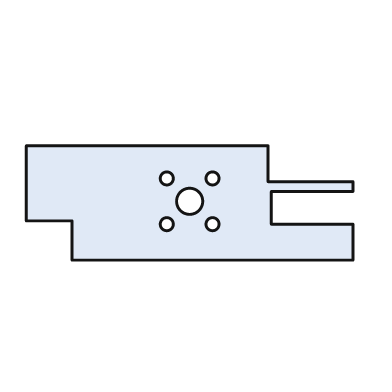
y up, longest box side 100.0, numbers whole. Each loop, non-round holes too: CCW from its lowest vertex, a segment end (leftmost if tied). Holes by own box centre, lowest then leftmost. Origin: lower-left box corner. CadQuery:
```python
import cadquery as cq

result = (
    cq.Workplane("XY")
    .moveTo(14.0, 0.0)
    .lineTo(100.0, 0.0)
    .lineTo(100.0, 11.0)
    .lineTo(75.0, 11.0)
    .lineTo(75.0, 21.0)
    .lineTo(100.0, 21.0)
    .lineTo(100.0, 24.0)
    .lineTo(74.0, 24.0)
    .lineTo(74.0, 35.0)
    .lineTo(0.0, 35.0)
    .lineTo(0.0, 12.0)
    .lineTo(14.0, 12.0)
    .close()
    .moveTo(43.0, 11.0)
    .circle(2.0)
    .moveTo(57.0, 11.0)
    .circle(2.0)
    .moveTo(50.0, 18.0)
    .circle(4.0)
    .moveTo(43.0, 25.0)
    .circle(2.0)
    .moveTo(57.0, 25.0)
    .circle(2.0)
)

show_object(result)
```